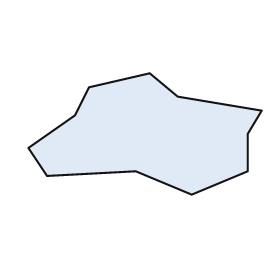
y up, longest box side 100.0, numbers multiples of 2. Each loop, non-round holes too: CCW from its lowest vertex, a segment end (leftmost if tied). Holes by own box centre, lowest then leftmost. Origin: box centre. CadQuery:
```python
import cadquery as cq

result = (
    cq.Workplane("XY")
    .moveTo(20.0, -26.0)
    .lineTo(44.0, -16.0)
    .lineTo(44.0, 0.0)
    .lineTo(50.0, 10.0)
    .lineTo(14.0, 16.0)
    .lineTo(2.0, 26.0)
    .lineTo(-24.0, 20.0)
    .lineTo(-30.0, 8.0)
    .lineTo(-50.0, -6.0)
    .lineTo(-42.0, -18.0)
    .lineTo(-4.0, -16.0)
    .close()
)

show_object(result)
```